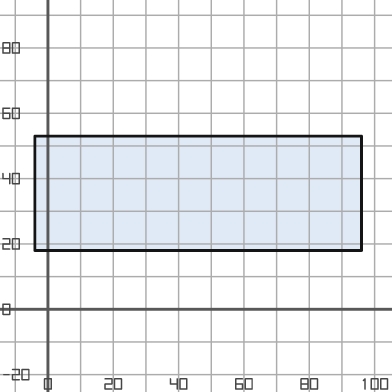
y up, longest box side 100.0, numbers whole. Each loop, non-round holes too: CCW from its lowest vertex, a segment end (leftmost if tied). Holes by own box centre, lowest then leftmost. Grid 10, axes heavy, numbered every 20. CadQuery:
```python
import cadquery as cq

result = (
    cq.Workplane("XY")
    .moveTo(-4.0, 18.0)
    .lineTo(96.0, 18.0)
    .lineTo(96.0, 53.0)
    .lineTo(-4.0, 53.0)
    .close()
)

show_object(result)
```